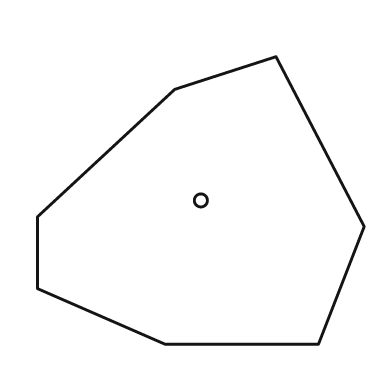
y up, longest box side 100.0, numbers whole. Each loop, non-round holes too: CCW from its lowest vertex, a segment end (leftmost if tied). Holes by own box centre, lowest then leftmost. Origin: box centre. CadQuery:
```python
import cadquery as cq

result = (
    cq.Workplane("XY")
    .moveTo(-11.0, -44.0)
    .lineTo(36.0, -44.0)
    .lineTo(50.0, -8.0)
    .lineTo(23.0, 44.0)
    .lineTo(-8.0, 34.0)
    .lineTo(-50.0, -5.0)
    .lineTo(-50.0, -27.0)
    .close()
    .moveTo(0.0, 0.0)
    .circle(2.0)
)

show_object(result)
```